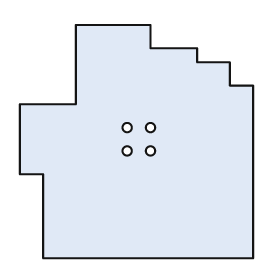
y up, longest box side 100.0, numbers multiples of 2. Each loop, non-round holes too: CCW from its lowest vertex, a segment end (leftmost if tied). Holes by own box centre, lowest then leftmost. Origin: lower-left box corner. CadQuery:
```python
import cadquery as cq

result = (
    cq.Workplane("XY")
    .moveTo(10.0, 0.0)
    .lineTo(100.0, 0.0)
    .lineTo(100.0, 74.0)
    .lineTo(90.0, 74.0)
    .lineTo(90.0, 84.0)
    .lineTo(76.0, 84.0)
    .lineTo(76.0, 90.0)
    .lineTo(56.0, 90.0)
    .lineTo(56.0, 100.0)
    .lineTo(24.0, 100.0)
    .lineTo(24.0, 66.0)
    .lineTo(0.0, 66.0)
    .lineTo(0.0, 36.0)
    .lineTo(10.0, 36.0)
    .close()
    .moveTo(46.0, 46.0)
    .circle(2.0)
    .moveTo(56.0, 46.0)
    .circle(2.0)
    .moveTo(46.0, 56.0)
    .circle(2.0)
    .moveTo(56.0, 56.0)
    .circle(2.0)
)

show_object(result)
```